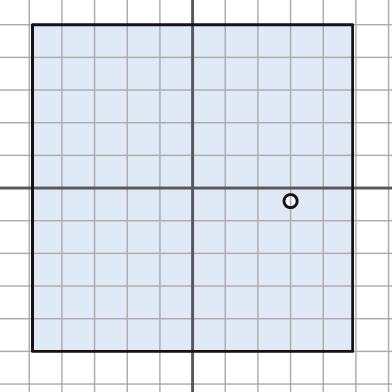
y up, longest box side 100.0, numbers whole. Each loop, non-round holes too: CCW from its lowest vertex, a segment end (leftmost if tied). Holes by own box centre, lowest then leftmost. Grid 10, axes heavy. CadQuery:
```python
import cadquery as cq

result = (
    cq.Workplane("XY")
    .moveTo(-49.0, -50.0)
    .lineTo(49.0, -50.0)
    .lineTo(49.0, 50.0)
    .lineTo(-49.0, 50.0)
    .close()
    .moveTo(30.0, -4.0)
    .circle(2.0)
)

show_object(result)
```